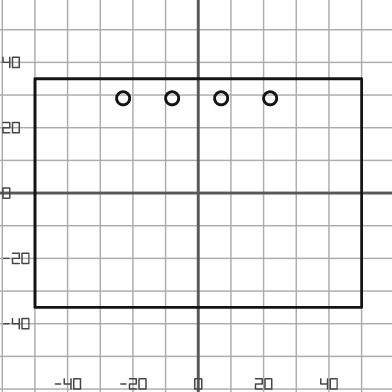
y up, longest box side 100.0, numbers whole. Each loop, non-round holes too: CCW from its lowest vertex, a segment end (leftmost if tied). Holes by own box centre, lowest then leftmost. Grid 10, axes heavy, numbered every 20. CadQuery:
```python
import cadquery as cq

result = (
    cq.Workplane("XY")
    .moveTo(-50.0, -35.0)
    .lineTo(50.0, -35.0)
    .lineTo(50.0, 35.0)
    .lineTo(-50.0, 35.0)
    .close()
    .moveTo(-23.0, 29.0)
    .circle(2.0)
    .moveTo(-8.0, 29.0)
    .circle(2.0)
    .moveTo(7.0, 29.0)
    .circle(2.0)
    .moveTo(22.0, 29.0)
    .circle(2.0)
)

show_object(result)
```